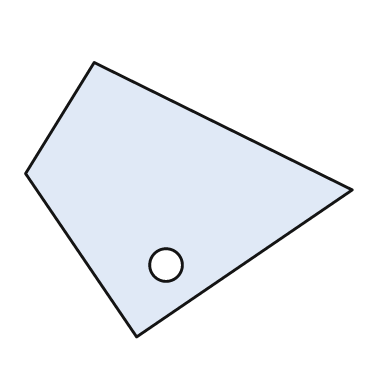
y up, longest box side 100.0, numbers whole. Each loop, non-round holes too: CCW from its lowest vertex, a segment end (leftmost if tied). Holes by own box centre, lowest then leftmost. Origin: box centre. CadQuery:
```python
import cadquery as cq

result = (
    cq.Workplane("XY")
    .moveTo(-16.0, -42.0)
    .lineTo(50.0, 3.0)
    .lineTo(-29.0, 42.0)
    .lineTo(-50.0, 8.0)
    .close()
    .moveTo(-7.0, -20.0)
    .circle(5.0)
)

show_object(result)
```